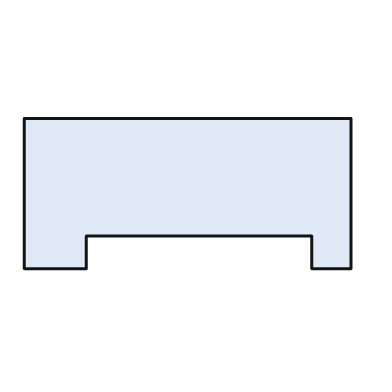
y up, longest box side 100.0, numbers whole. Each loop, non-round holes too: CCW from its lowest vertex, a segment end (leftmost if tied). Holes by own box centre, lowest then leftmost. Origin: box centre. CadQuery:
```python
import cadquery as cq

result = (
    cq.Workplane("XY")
    .moveTo(-50.0, -23.0)
    .lineTo(-31.0, -23.0)
    .lineTo(-31.0, -13.0)
    .lineTo(38.0, -13.0)
    .lineTo(38.0, -23.0)
    .lineTo(50.0, -23.0)
    .lineTo(50.0, 23.0)
    .lineTo(-50.0, 23.0)
    .close()
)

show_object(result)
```